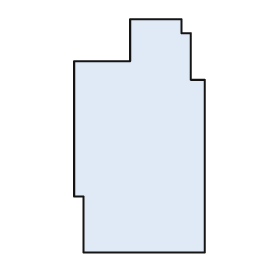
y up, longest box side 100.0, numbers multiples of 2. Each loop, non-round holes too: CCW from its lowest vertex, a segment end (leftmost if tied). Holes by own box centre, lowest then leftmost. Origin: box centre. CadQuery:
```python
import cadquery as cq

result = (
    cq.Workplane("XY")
    .moveTo(-24.0, -50.0)
    .lineTo(28.0, -50.0)
    .lineTo(28.0, 24.0)
    .lineTo(22.0, 24.0)
    .lineTo(22.0, 44.0)
    .lineTo(18.0, 44.0)
    .lineTo(18.0, 50.0)
    .lineTo(-4.0, 50.0)
    .lineTo(-4.0, 32.0)
    .lineTo(-28.0, 32.0)
    .lineTo(-28.0, -26.0)
    .lineTo(-24.0, -26.0)
    .close()
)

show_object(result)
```